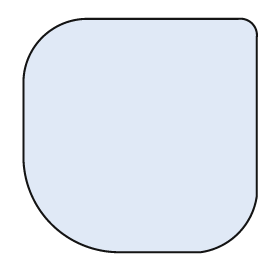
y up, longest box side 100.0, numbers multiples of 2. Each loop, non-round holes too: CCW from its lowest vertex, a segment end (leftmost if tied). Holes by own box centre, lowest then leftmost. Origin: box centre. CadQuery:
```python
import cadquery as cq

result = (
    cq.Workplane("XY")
    .moveTo(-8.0, -50.0)
    .lineTo(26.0, -50.0)
    .threePointArc((42.0, -42.0), (50.0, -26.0))
    .lineTo(50.0, 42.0)
    .threePointArc((48.0, 48.0), (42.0, 50.0))
    .lineTo(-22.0, 50.0)
    .threePointArc((-42.0, 42.0), (-50.0, 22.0))
    .lineTo(-50.0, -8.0)
    .threePointArc((-38.0, -38.0), (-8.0, -50.0))
    .close()
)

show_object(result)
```